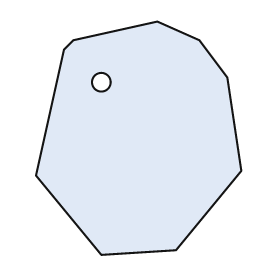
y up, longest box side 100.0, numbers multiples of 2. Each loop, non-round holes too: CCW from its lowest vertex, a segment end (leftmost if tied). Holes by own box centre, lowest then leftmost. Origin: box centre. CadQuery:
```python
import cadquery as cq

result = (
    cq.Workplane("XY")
    .moveTo(-16.0, -50.0)
    .lineTo(16.0, -48.0)
    .lineTo(44.0, -14.0)
    .lineTo(38.0, 26.0)
    .lineTo(26.0, 42.0)
    .lineTo(8.0, 50.0)
    .lineTo(-28.0, 42.0)
    .lineTo(-32.0, 38.0)
    .lineTo(-44.0, -16.0)
    .close()
    .moveTo(-16.0, 24.0)
    .circle(4.0)
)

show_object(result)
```